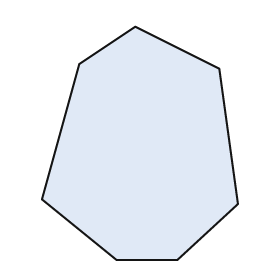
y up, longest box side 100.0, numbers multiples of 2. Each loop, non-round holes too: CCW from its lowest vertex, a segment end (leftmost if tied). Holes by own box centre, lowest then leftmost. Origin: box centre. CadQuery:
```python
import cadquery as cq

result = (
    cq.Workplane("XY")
    .moveTo(-10.0, -50.0)
    .lineTo(16.0, -50.0)
    .lineTo(42.0, -26.0)
    .lineTo(34.0, 32.0)
    .lineTo(-2.0, 50.0)
    .lineTo(-26.0, 34.0)
    .lineTo(-42.0, -24.0)
    .close()
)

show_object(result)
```